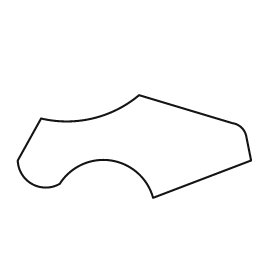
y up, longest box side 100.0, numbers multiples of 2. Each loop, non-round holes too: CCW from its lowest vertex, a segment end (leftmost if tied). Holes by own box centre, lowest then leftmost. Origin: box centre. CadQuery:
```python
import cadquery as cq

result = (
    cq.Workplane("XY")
    .moveTo(8.0, -22.0)
    .lineTo(50.0, -6.0)
    .lineTo(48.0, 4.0)
    .threePointArc((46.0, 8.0), (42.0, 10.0))
    .lineTo(2.0, 22.0)
    .threePointArc((-18.0, 12.0), (-40.0, 12.0))
    .lineTo(-50.0, -6.0)
    .threePointArc((-44.0, -16.0), (-32.0, -16.0))
    .threePointArc((-10.0, -6.0), (8.0, -22.0))
    .close()
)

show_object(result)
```